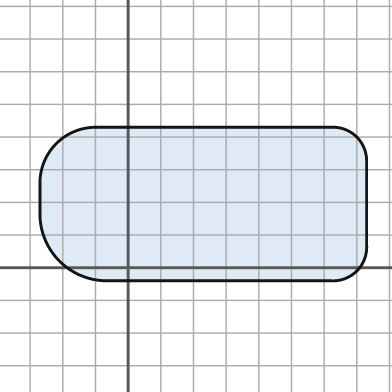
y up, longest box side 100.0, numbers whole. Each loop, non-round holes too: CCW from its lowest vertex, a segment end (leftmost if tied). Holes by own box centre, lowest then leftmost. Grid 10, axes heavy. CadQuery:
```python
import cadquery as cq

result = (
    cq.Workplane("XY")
    .moveTo(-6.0, -4.0)
    .lineTo(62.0, -4.0)
    .threePointArc((70.0, -1.0), (73.0, 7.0))
    .lineTo(73.0, 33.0)
    .threePointArc((70.0, 40.0), (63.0, 43.0))
    .lineTo(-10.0, 43.0)
    .threePointArc((-22.0, 38.0), (-27.0, 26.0))
    .lineTo(-27.0, 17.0)
    .threePointArc((-21.0, 2.0), (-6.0, -4.0))
    .close()
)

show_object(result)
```